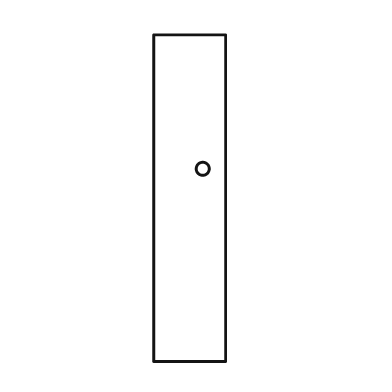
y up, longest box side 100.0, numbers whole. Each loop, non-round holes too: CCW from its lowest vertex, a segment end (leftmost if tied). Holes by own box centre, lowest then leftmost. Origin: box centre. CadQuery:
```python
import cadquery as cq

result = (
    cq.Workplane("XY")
    .moveTo(-11.0, -50.0)
    .lineTo(11.0, -50.0)
    .lineTo(11.0, 50.0)
    .lineTo(-11.0, 50.0)
    .close()
    .moveTo(4.0, 9.0)
    .circle(2.0)
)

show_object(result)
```